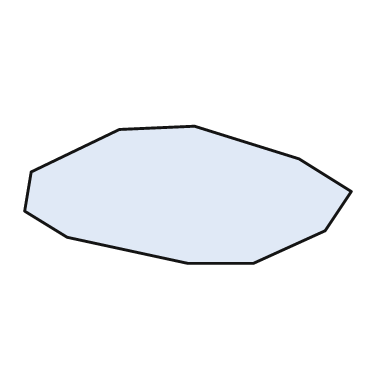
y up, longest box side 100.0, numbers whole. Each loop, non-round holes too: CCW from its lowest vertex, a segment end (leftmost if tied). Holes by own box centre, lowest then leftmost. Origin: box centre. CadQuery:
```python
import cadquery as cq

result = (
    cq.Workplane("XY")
    .moveTo(0.0, -21.0)
    .lineTo(20.0, -21.0)
    .lineTo(42.0, -11.0)
    .lineTo(50.0, 1.0)
    .lineTo(34.0, 11.0)
    .lineTo(2.0, 21.0)
    .lineTo(-21.0, 20.0)
    .lineTo(-48.0, 7.0)
    .lineTo(-50.0, -5.0)
    .lineTo(-37.0, -13.0)
    .close()
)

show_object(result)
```